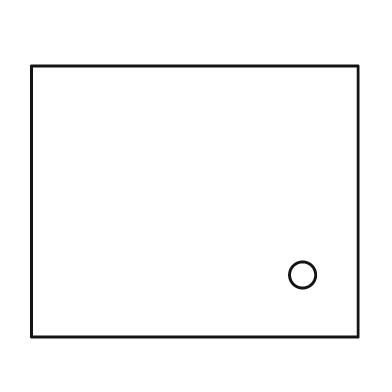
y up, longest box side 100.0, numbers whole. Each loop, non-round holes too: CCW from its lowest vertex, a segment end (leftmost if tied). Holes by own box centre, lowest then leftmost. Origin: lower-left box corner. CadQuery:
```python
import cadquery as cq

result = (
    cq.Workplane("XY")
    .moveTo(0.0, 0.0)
    .lineTo(100.0, 0.0)
    .lineTo(100.0, 83.0)
    .lineTo(0.0, 83.0)
    .close()
    .moveTo(83.0, 19.0)
    .circle(4.0)
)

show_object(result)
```